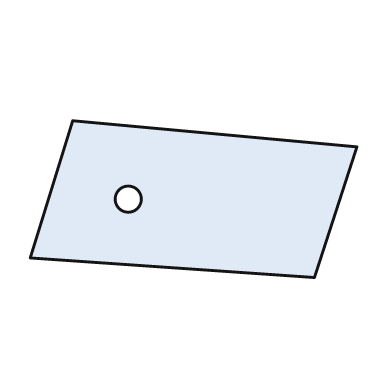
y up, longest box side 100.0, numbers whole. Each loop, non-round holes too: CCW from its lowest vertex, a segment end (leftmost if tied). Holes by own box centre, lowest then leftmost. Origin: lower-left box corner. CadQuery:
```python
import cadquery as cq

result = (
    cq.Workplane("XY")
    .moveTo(87.0, 0.0)
    .lineTo(100.0, 40.0)
    .lineTo(13.0, 48.0)
    .lineTo(0.0, 6.0)
    .close()
    .moveTo(30.0, 24.0)
    .circle(4.0)
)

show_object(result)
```